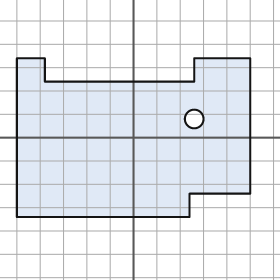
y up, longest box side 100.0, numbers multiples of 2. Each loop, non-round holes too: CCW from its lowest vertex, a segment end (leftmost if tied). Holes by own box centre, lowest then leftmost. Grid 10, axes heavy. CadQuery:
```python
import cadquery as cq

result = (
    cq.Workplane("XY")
    .moveTo(-50.0, -34.0)
    .lineTo(24.0, -34.0)
    .lineTo(24.0, -24.0)
    .lineTo(50.0, -24.0)
    .lineTo(50.0, 34.0)
    .lineTo(26.0, 34.0)
    .lineTo(26.0, 24.0)
    .lineTo(-38.0, 24.0)
    .lineTo(-38.0, 34.0)
    .lineTo(-50.0, 34.0)
    .close()
    .moveTo(26.0, 8.0)
    .circle(4.0)
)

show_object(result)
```